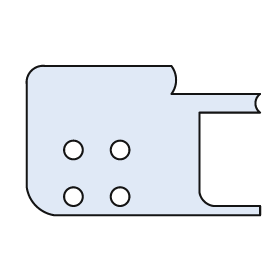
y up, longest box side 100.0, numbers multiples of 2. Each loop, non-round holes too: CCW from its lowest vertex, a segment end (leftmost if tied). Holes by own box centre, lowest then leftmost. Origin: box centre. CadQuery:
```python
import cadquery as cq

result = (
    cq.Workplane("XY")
    .moveTo(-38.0, -32.0)
    .lineTo(50.0, -32.0)
    .lineTo(50.0, -28.0)
    .lineTo(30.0, -28.0)
    .threePointArc((26.0, -26.0), (24.0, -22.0))
    .lineTo(24.0, 12.0)
    .lineTo(50.0, 12.0)
    .threePointArc((48.0, 16.0), (50.0, 20.0))
    .lineTo(12.0, 20.0)
    .threePointArc((14.0, 26.0), (12.0, 32.0))
    .lineTo(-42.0, 32.0)
    .threePointArc((-48.0, 30.0), (-50.0, 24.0))
    .lineTo(-50.0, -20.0)
    .threePointArc((-46.0, -28.0), (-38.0, -32.0))
    .close()
    .moveTo(-30.0, -24.0)
    .circle(4.0)
    .moveTo(-10.0, -24.0)
    .circle(4.0)
    .moveTo(-30.0, -4.0)
    .circle(4.0)
    .moveTo(-10.0, -4.0)
    .circle(4.0)
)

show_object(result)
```